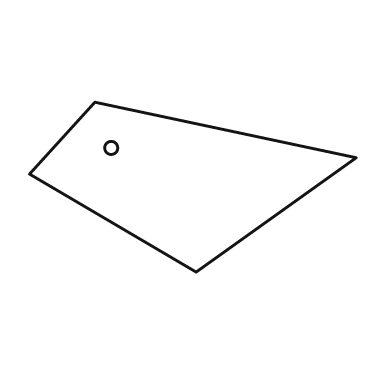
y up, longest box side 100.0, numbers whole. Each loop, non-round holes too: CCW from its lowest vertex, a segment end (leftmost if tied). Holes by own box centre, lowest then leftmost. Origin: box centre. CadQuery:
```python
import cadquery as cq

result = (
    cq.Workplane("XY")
    .moveTo(1.0, -26.0)
    .lineTo(50.0, 9.0)
    .lineTo(-30.0, 26.0)
    .lineTo(-50.0, 4.0)
    .close()
    .moveTo(-25.0, 12.0)
    .circle(2.0)
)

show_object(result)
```